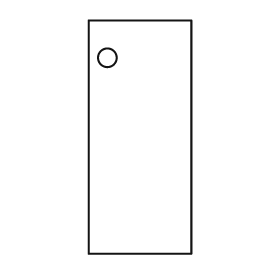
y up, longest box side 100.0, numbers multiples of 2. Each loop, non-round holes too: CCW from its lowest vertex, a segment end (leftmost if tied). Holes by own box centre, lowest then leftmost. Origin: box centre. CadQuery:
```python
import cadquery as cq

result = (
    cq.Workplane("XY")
    .moveTo(-22.0, -50.0)
    .lineTo(22.0, -50.0)
    .lineTo(22.0, 50.0)
    .lineTo(-22.0, 50.0)
    .close()
    .moveTo(-14.0, 34.0)
    .circle(4.0)
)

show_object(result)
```